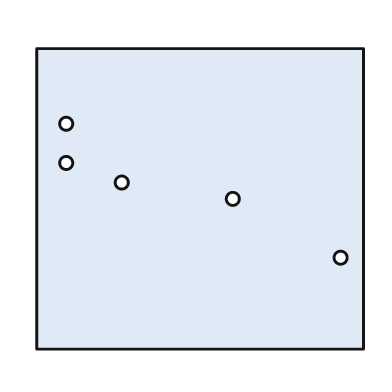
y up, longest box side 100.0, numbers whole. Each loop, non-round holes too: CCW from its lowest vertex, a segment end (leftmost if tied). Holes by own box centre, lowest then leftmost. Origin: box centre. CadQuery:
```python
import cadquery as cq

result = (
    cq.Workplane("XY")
    .moveTo(-50.0, -46.0)
    .lineTo(50.0, -46.0)
    .lineTo(50.0, 46.0)
    .lineTo(-50.0, 46.0)
    .close()
    .moveTo(43.0, -18.0)
    .circle(2.0)
    .moveTo(10.0, 0.0)
    .circle(2.0)
    .moveTo(-24.0, 5.0)
    .circle(2.0)
    .moveTo(-41.0, 11.0)
    .circle(2.0)
    .moveTo(-41.0, 23.0)
    .circle(2.0)
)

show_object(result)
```